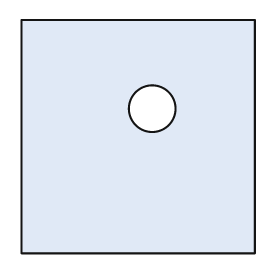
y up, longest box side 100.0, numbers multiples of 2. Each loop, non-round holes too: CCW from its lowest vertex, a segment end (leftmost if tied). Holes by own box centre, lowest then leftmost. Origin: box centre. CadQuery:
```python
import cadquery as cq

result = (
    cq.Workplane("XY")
    .moveTo(-50.0, -50.0)
    .lineTo(50.0, -50.0)
    .lineTo(50.0, 50.0)
    .lineTo(-50.0, 50.0)
    .close()
    .moveTo(6.0, 12.0)
    .circle(10.0)
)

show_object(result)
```